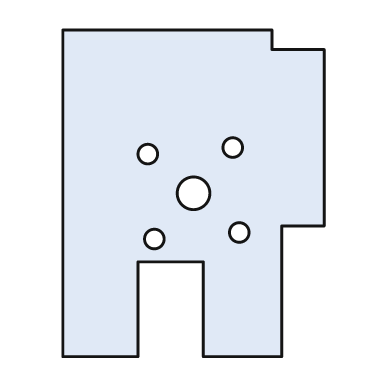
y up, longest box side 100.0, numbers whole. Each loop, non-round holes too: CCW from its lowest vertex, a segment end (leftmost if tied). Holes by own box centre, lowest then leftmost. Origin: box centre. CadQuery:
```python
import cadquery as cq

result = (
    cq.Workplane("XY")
    .moveTo(-40.0, -50.0)
    .lineTo(-17.0, -50.0)
    .lineTo(-17.0, -21.0)
    .lineTo(3.0, -21.0)
    .lineTo(3.0, -50.0)
    .lineTo(27.0, -50.0)
    .lineTo(27.0, -10.0)
    .lineTo(40.0, -10.0)
    .lineTo(40.0, 44.0)
    .lineTo(24.0, 44.0)
    .lineTo(24.0, 50.0)
    .lineTo(-40.0, 50.0)
    .close()
    .moveTo(-12.0, -14.0)
    .circle(3.0)
    .moveTo(14.0, -12.0)
    .circle(3.0)
    .moveTo(0.0, 0.0)
    .circle(5.0)
    .moveTo(-14.0, 12.0)
    .circle(3.0)
    .moveTo(12.0, 14.0)
    .circle(3.0)
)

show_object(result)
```